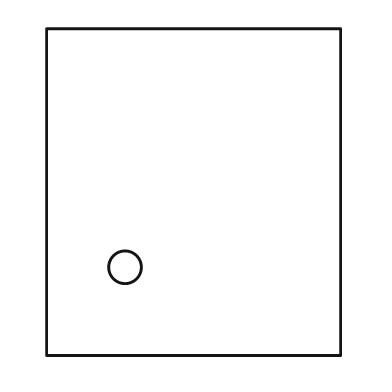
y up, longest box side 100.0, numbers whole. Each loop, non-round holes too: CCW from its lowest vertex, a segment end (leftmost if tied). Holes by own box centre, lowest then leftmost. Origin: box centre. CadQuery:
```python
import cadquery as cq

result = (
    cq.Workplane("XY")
    .moveTo(-45.0, -50.0)
    .lineTo(45.0, -50.0)
    .lineTo(45.0, 50.0)
    .lineTo(-45.0, 50.0)
    .close()
    .moveTo(-21.0, -23.0)
    .circle(5.0)
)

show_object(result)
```